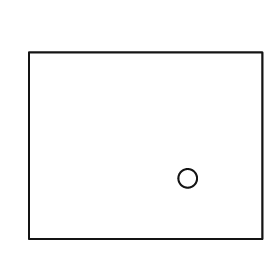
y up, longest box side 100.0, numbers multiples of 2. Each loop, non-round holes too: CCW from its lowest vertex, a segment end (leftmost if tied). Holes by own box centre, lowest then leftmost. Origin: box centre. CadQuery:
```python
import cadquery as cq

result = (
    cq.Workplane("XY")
    .moveTo(-50.0, -40.0)
    .lineTo(50.0, -40.0)
    .lineTo(50.0, 40.0)
    .lineTo(-50.0, 40.0)
    .close()
    .moveTo(18.0, -14.0)
    .circle(4.0)
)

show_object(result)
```